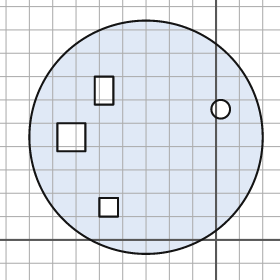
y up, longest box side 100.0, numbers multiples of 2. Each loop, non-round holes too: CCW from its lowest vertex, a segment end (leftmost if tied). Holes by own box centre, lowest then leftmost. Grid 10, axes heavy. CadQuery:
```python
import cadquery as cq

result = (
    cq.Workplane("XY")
    .moveTo(-30.0, 44.0)
    .circle(50.0)
    .moveTo(-50.0, 10.0)
    .lineTo(-42.0, 10.0)
    .lineTo(-42.0, 18.0)
    .lineTo(-50.0, 18.0)
    .close()
    .moveTo(-68.0, 38.0)
    .lineTo(-56.0, 38.0)
    .lineTo(-56.0, 50.0)
    .lineTo(-68.0, 50.0)
    .close()
    .moveTo(2.0, 56.0)
    .circle(4.0)
    .moveTo(-52.0, 58.0)
    .lineTo(-44.0, 58.0)
    .lineTo(-44.0, 70.0)
    .lineTo(-52.0, 70.0)
    .close()
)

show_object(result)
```